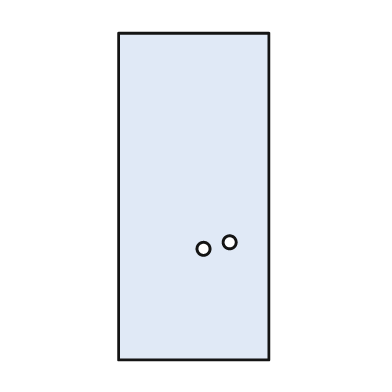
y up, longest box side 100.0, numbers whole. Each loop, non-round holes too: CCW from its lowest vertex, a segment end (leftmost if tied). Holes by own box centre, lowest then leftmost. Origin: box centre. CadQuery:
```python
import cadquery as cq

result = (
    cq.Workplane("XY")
    .moveTo(-23.0, -50.0)
    .lineTo(23.0, -50.0)
    .lineTo(23.0, 50.0)
    .lineTo(-23.0, 50.0)
    .close()
    .moveTo(3.0, -16.0)
    .circle(2.0)
    .moveTo(11.0, -14.0)
    .circle(2.0)
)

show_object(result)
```